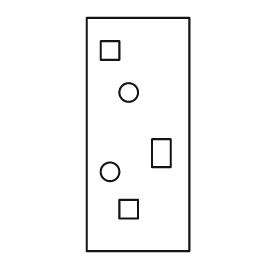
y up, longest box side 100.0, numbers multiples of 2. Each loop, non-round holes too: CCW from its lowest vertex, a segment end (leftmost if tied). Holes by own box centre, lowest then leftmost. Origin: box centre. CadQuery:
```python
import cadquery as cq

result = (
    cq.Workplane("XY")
    .moveTo(-22.0, -50.0)
    .lineTo(22.0, -50.0)
    .lineTo(22.0, 50.0)
    .lineTo(-22.0, 50.0)
    .close()
    .moveTo(-8.0, -36.0)
    .lineTo(0.0, -36.0)
    .lineTo(0.0, -28.0)
    .lineTo(-8.0, -28.0)
    .close()
    .moveTo(-12.0, -16.0)
    .circle(4.0)
    .moveTo(6.0, -14.0)
    .lineTo(14.0, -14.0)
    .lineTo(14.0, -2.0)
    .lineTo(6.0, -2.0)
    .close()
    .moveTo(-4.0, 18.0)
    .circle(4.0)
    .moveTo(-16.0, 32.0)
    .lineTo(-8.0, 32.0)
    .lineTo(-8.0, 40.0)
    .lineTo(-16.0, 40.0)
    .close()
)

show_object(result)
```